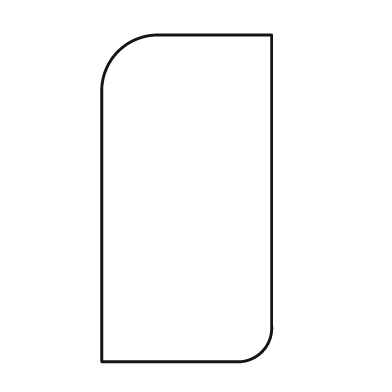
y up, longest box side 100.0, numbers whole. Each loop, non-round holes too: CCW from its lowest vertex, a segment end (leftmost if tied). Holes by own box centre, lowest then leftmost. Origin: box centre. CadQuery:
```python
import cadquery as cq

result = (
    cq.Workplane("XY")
    .moveTo(-26.0, -50.0)
    .lineTo(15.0, -50.0)
    .threePointArc((23.0, -47.0), (26.0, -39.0))
    .lineTo(26.0, 50.0)
    .lineTo(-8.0, 50.0)
    .threePointArc((-21.0, 45.0), (-26.0, 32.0))
    .close()
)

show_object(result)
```